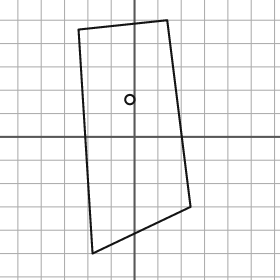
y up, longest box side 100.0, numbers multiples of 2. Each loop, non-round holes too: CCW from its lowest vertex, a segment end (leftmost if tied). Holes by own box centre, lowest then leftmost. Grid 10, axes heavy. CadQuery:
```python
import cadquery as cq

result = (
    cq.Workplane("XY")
    .moveTo(-18.0, -50.0)
    .lineTo(24.0, -30.0)
    .lineTo(14.0, 50.0)
    .lineTo(-24.0, 46.0)
    .close()
    .moveTo(-2.0, 16.0)
    .circle(2.0)
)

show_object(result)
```